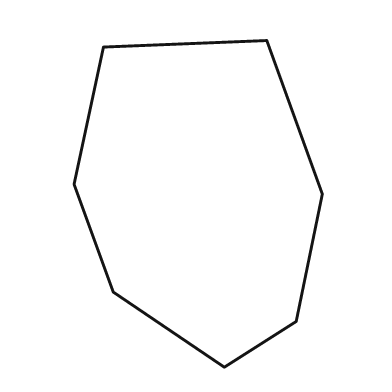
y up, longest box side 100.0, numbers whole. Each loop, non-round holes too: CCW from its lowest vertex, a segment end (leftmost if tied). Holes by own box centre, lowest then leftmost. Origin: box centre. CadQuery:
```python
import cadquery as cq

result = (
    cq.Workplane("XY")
    .moveTo(8.0, -50.0)
    .lineTo(30.0, -36.0)
    .lineTo(38.0, 3.0)
    .lineTo(21.0, 50.0)
    .lineTo(-29.0, 48.0)
    .lineTo(-38.0, 6.0)
    .lineTo(-26.0, -27.0)
    .close()
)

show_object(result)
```